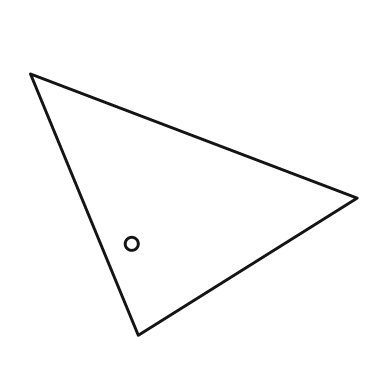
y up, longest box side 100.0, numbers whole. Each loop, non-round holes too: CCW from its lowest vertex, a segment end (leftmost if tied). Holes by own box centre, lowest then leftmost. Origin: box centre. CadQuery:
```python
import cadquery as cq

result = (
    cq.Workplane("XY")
    .moveTo(-17.0, -40.0)
    .lineTo(50.0, 2.0)
    .lineTo(-50.0, 40.0)
    .close()
    .moveTo(-19.0, -12.0)
    .circle(2.0)
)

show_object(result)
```